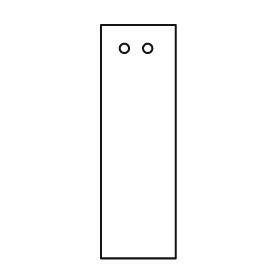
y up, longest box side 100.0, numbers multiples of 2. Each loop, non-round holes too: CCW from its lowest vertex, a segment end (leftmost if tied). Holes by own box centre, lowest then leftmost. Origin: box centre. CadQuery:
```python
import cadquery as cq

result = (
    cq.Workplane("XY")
    .moveTo(-16.0, -50.0)
    .lineTo(16.0, -50.0)
    .lineTo(16.0, 50.0)
    .lineTo(-16.0, 50.0)
    .close()
    .moveTo(-6.0, 40.0)
    .circle(2.0)
    .moveTo(4.0, 40.0)
    .circle(2.0)
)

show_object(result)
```